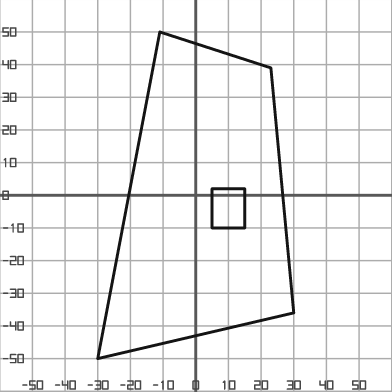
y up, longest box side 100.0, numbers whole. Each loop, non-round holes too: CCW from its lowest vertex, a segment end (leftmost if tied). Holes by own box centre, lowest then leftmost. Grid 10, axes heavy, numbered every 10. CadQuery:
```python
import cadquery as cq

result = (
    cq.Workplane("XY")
    .moveTo(-30.0, -50.0)
    .lineTo(30.0, -36.0)
    .lineTo(23.0, 39.0)
    .lineTo(-11.0, 50.0)
    .close()
    .moveTo(5.0, -10.0)
    .lineTo(15.0, -10.0)
    .lineTo(15.0, 2.0)
    .lineTo(5.0, 2.0)
    .close()
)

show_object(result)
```